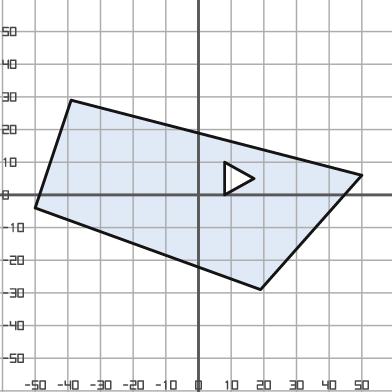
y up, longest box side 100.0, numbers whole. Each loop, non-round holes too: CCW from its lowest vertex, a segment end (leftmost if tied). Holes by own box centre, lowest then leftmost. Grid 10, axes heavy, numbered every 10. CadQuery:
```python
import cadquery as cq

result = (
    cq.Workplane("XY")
    .moveTo(19.0, -29.0)
    .lineTo(50.0, 6.0)
    .lineTo(-39.0, 29.0)
    .lineTo(-50.0, -4.0)
    .close()
    .moveTo(8.0, 0.0)
    .lineTo(17.0, 5.0)
    .lineTo(8.0, 10.0)
    .close()
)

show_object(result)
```